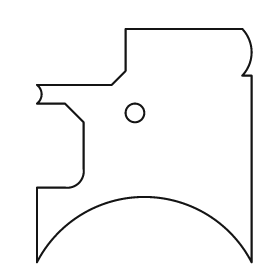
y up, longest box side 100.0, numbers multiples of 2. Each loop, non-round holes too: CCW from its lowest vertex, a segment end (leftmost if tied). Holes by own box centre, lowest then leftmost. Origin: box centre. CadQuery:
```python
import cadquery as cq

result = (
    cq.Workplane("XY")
    .moveTo(-46.0, -50.0)
    .threePointArc((0.0, -22.0), (46.0, -50.0))
    .lineTo(46.0, 30.0)
    .lineTo(42.0, 30.0)
    .threePointArc((46.0, 40.0), (42.0, 50.0))
    .lineTo(-8.0, 50.0)
    .lineTo(-8.0, 32.0)
    .lineTo(-14.0, 26.0)
    .lineTo(-46.0, 26.0)
    .threePointArc((-44.0, 22.0), (-46.0, 18.0))
    .lineTo(-34.0, 18.0)
    .lineTo(-26.0, 10.0)
    .lineTo(-26.0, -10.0)
    .threePointArc((-28.0, -16.0), (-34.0, -18.0))
    .lineTo(-46.0, -18.0)
    .close()
    .moveTo(-4.0, 14.0)
    .circle(4.0)
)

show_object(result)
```